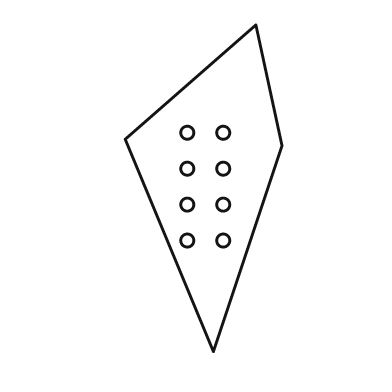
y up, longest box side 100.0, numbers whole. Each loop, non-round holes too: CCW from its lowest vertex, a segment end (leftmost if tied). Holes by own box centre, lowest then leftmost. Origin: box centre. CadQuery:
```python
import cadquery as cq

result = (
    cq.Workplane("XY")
    .moveTo(3.0, -50.0)
    .lineTo(24.0, 13.0)
    .lineTo(16.0, 50.0)
    .lineTo(-24.0, 15.0)
    .close()
    .moveTo(-5.0, -16.0)
    .circle(2.0)
    .moveTo(6.0, -16.0)
    .circle(2.0)
    .moveTo(-5.0, -5.0)
    .circle(2.0)
    .moveTo(6.0, -5.0)
    .circle(2.0)
    .moveTo(-5.0, 6.0)
    .circle(2.0)
    .moveTo(6.0, 6.0)
    .circle(2.0)
    .moveTo(-5.0, 17.0)
    .circle(2.0)
    .moveTo(6.0, 17.0)
    .circle(2.0)
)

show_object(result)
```